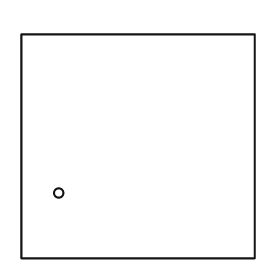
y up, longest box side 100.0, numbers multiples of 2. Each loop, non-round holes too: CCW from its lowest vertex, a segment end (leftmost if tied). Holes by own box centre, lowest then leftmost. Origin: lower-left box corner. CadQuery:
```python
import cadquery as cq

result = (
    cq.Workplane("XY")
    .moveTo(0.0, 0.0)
    .lineTo(100.0, 0.0)
    .lineTo(100.0, 96.0)
    .lineTo(0.0, 96.0)
    .close()
    .moveTo(16.0, 28.0)
    .circle(2.0)
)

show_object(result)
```